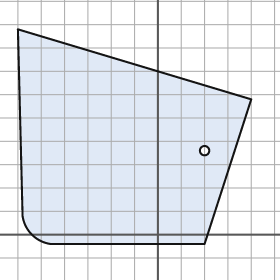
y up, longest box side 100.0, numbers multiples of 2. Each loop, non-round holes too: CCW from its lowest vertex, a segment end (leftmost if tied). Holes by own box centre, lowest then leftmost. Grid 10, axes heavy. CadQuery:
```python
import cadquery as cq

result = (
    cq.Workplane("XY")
    .moveTo(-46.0, -4.0)
    .lineTo(20.0, -4.0)
    .lineTo(40.0, 58.0)
    .lineTo(-60.0, 88.0)
    .lineTo(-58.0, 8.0)
    .threePointArc((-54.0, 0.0), (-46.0, -4.0))
    .close()
    .moveTo(20.0, 36.0)
    .circle(2.0)
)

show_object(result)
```